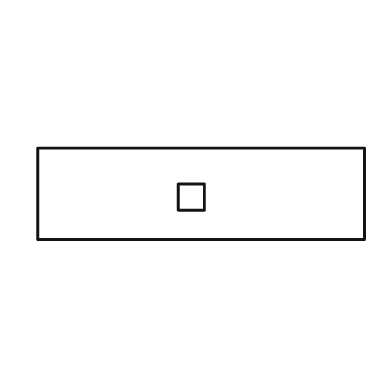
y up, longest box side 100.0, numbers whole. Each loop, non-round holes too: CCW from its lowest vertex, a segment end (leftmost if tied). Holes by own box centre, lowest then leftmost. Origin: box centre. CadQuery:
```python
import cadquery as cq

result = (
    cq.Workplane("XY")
    .moveTo(-50.0, -14.0)
    .lineTo(50.0, -14.0)
    .lineTo(50.0, 14.0)
    .lineTo(-50.0, 14.0)
    .close()
    .moveTo(-7.0, -5.0)
    .lineTo(1.0, -5.0)
    .lineTo(1.0, 3.0)
    .lineTo(-7.0, 3.0)
    .close()
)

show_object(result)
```